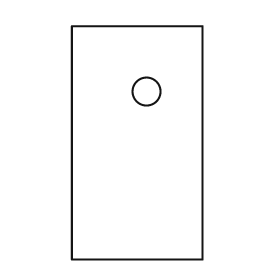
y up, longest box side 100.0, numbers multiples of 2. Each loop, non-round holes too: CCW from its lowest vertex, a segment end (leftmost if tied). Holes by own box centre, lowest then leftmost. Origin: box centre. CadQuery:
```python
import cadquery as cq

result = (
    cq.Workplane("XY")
    .moveTo(-28.0, -50.0)
    .lineTo(28.0, -50.0)
    .lineTo(28.0, 50.0)
    .lineTo(-28.0, 50.0)
    .close()
    .moveTo(4.0, 22.0)
    .circle(6.0)
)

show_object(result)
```